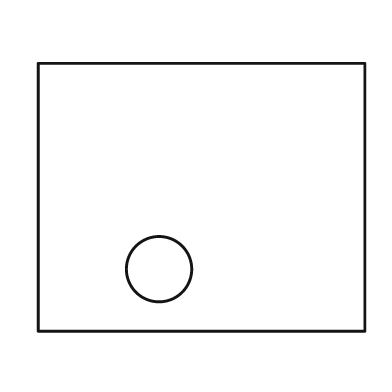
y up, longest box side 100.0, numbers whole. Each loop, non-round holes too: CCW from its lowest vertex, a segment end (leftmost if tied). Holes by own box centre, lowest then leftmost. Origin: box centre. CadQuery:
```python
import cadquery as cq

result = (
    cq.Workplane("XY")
    .moveTo(-50.0, -41.0)
    .lineTo(50.0, -41.0)
    .lineTo(50.0, 41.0)
    .lineTo(-50.0, 41.0)
    .close()
    .moveTo(-13.0, -22.0)
    .circle(10.0)
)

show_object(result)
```